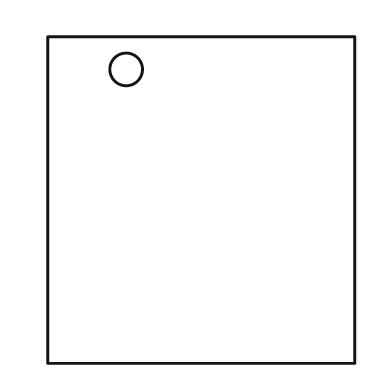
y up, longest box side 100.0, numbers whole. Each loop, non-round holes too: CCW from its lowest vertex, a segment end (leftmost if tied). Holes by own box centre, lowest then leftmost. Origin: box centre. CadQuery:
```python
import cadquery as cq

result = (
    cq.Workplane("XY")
    .moveTo(-47.0, -50.0)
    .lineTo(47.0, -50.0)
    .lineTo(47.0, 50.0)
    .lineTo(-47.0, 50.0)
    .close()
    .moveTo(-23.0, 40.0)
    .circle(5.0)
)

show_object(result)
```